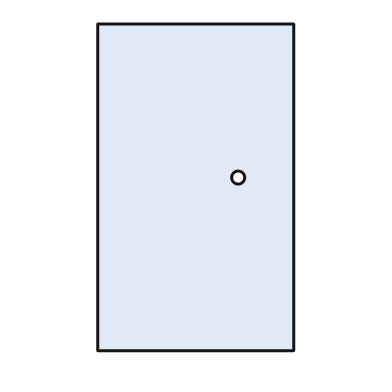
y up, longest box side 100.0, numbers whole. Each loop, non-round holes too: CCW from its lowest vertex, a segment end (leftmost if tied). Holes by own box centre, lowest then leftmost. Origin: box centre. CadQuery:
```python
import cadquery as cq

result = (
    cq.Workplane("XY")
    .moveTo(-30.0, -50.0)
    .lineTo(30.0, -50.0)
    .lineTo(30.0, 50.0)
    .lineTo(-30.0, 50.0)
    .close()
    .moveTo(13.0, 3.0)
    .circle(2.0)
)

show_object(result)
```